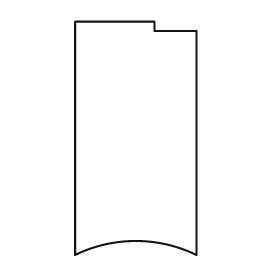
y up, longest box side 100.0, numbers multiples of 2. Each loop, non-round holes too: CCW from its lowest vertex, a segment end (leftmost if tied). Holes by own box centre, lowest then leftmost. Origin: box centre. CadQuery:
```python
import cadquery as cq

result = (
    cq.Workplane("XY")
    .moveTo(-26.0, -50.0)
    .threePointArc((0.0, -44.0), (26.0, -50.0))
    .lineTo(26.0, 46.0)
    .lineTo(8.0, 46.0)
    .lineTo(8.0, 50.0)
    .lineTo(-26.0, 50.0)
    .close()
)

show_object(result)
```